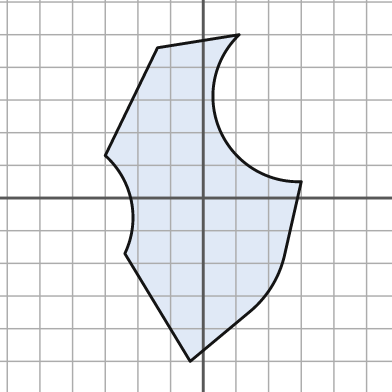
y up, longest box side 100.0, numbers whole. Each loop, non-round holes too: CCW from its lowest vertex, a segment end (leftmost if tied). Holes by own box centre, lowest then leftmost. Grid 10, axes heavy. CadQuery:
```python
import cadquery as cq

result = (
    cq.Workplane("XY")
    .moveTo(-4.0, -50.0)
    .lineTo(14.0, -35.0)
    .threePointArc((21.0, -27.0), (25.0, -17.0))
    .lineTo(30.0, 5.0)
    .threePointArc((5.0, 21.0), (11.0, 50.0))
    .lineTo(-14.0, 46.0)
    .lineTo(-30.0, 13.0)
    .threePointArc((-22.0, -1.0), (-24.0, -17.0))
    .close()
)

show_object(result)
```